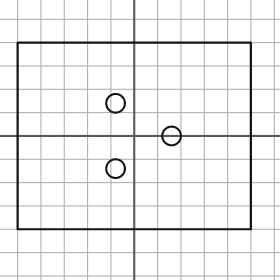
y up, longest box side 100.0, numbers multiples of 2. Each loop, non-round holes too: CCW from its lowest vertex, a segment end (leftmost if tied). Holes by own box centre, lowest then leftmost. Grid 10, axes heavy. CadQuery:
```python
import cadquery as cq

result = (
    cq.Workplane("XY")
    .moveTo(-50.0, -40.0)
    .lineTo(50.0, -40.0)
    .lineTo(50.0, 40.0)
    .lineTo(-50.0, 40.0)
    .close()
    .moveTo(-8.0, -14.0)
    .circle(4.0)
    .moveTo(16.0, 0.0)
    .circle(4.0)
    .moveTo(-8.0, 14.0)
    .circle(4.0)
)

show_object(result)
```